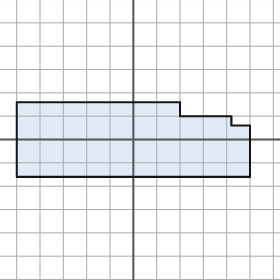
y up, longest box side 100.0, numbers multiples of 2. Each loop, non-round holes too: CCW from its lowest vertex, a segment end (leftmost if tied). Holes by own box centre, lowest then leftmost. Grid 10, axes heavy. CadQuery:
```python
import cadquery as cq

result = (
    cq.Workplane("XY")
    .moveTo(-50.0, -16.0)
    .lineTo(50.0, -16.0)
    .lineTo(50.0, 6.0)
    .lineTo(42.0, 6.0)
    .lineTo(42.0, 10.0)
    .lineTo(20.0, 10.0)
    .lineTo(20.0, 16.0)
    .lineTo(-50.0, 16.0)
    .close()
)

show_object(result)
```